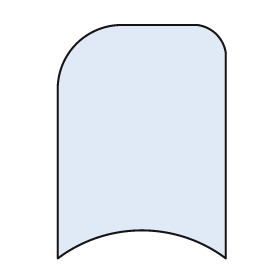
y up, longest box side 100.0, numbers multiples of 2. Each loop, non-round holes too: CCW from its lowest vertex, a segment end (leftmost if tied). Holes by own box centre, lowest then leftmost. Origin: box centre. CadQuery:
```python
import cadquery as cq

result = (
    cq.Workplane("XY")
    .moveTo(-36.0, -50.0)
    .threePointArc((0.0, -38.0), (36.0, -50.0))
    .lineTo(36.0, 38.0)
    .threePointArc((32.0, 46.0), (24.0, 50.0))
    .lineTo(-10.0, 50.0)
    .threePointArc((-28.0, 42.0), (-36.0, 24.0))
    .close()
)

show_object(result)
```